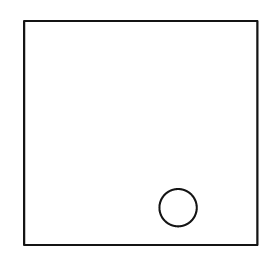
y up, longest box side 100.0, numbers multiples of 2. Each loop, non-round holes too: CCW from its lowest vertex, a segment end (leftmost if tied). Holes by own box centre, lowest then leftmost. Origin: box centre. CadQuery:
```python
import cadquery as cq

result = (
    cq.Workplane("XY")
    .moveTo(-50.0, -48.0)
    .lineTo(50.0, -48.0)
    .lineTo(50.0, 48.0)
    .lineTo(-50.0, 48.0)
    .close()
    .moveTo(16.0, -32.0)
    .circle(8.0)
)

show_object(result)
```